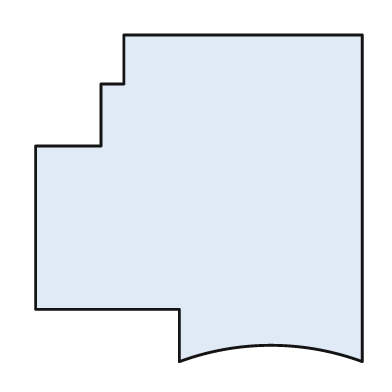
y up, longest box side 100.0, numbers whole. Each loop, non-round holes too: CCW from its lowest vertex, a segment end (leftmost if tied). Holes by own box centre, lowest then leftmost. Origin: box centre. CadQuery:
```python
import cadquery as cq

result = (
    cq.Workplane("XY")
    .moveTo(-6.0, -50.0)
    .threePointArc((22.0, -45.0), (50.0, -50.0))
    .lineTo(50.0, 50.0)
    .lineTo(-23.0, 50.0)
    .lineTo(-23.0, 35.0)
    .lineTo(-30.0, 35.0)
    .lineTo(-30.0, 16.0)
    .lineTo(-50.0, 16.0)
    .lineTo(-50.0, -34.0)
    .lineTo(-6.0, -34.0)
    .close()
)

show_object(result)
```